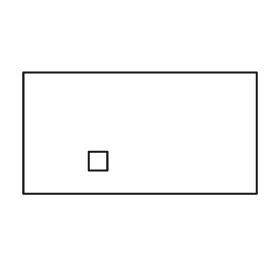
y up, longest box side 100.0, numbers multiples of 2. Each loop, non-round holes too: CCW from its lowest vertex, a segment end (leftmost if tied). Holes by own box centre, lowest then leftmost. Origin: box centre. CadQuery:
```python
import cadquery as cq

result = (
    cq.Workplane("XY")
    .moveTo(-50.0, -26.0)
    .lineTo(50.0, -26.0)
    .lineTo(50.0, 26.0)
    .lineTo(-50.0, 26.0)
    .close()
    .moveTo(-22.0, -16.0)
    .lineTo(-14.0, -16.0)
    .lineTo(-14.0, -8.0)
    .lineTo(-22.0, -8.0)
    .close()
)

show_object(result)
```